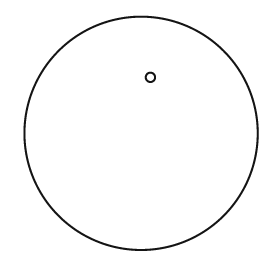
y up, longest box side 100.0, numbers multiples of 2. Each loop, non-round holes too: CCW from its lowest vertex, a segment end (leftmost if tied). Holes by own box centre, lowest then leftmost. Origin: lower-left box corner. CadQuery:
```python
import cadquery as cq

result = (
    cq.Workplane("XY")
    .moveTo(50.0, 50.0)
    .circle(50.0)
    .moveTo(54.0, 74.0)
    .circle(2.0)
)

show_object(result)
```